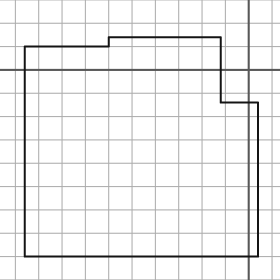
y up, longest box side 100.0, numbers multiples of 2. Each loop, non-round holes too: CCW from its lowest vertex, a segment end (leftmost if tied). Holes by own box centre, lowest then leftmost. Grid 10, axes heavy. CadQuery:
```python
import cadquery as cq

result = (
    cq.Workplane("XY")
    .moveTo(-96.0, -80.0)
    .lineTo(4.0, -80.0)
    .lineTo(4.0, -14.0)
    .lineTo(-12.0, -14.0)
    .lineTo(-12.0, 14.0)
    .lineTo(-60.0, 14.0)
    .lineTo(-60.0, 10.0)
    .lineTo(-96.0, 10.0)
    .close()
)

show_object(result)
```